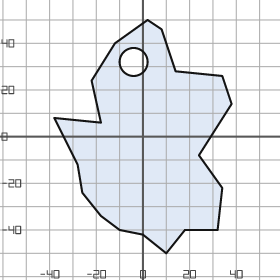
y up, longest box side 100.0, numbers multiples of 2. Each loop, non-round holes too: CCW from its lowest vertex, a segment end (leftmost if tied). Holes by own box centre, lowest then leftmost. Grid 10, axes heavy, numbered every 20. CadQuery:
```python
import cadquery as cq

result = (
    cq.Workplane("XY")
    .moveTo(10.0, -50.0)
    .lineTo(18.0, -40.0)
    .lineTo(32.0, -40.0)
    .lineTo(34.0, -22.0)
    .lineTo(24.0, -8.0)
    .lineTo(38.0, 14.0)
    .lineTo(34.0, 26.0)
    .lineTo(14.0, 28.0)
    .lineTo(8.0, 46.0)
    .lineTo(2.0, 50.0)
    .lineTo(-12.0, 40.0)
    .lineTo(-22.0, 24.0)
    .lineTo(-18.0, 6.0)
    .lineTo(-38.0, 8.0)
    .lineTo(-28.0, -12.0)
    .lineTo(-26.0, -24.0)
    .lineTo(-18.0, -34.0)
    .lineTo(-10.0, -40.0)
    .lineTo(0.0, -42.0)
    .close()
    .moveTo(-4.0, 32.0)
    .circle(6.0)
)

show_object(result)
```